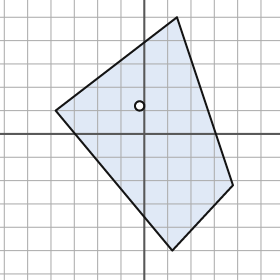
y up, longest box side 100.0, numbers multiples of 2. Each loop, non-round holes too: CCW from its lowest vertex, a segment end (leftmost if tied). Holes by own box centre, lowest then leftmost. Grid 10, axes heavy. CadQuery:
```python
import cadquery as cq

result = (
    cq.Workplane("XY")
    .moveTo(12.0, -50.0)
    .lineTo(38.0, -22.0)
    .lineTo(14.0, 50.0)
    .lineTo(-38.0, 10.0)
    .close()
    .moveTo(-2.0, 12.0)
    .circle(2.0)
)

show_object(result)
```